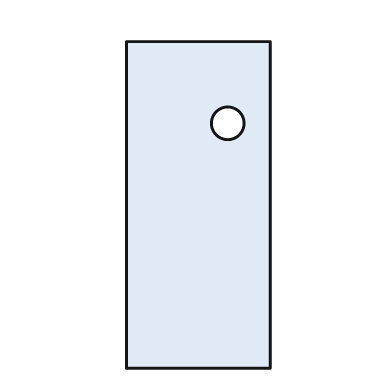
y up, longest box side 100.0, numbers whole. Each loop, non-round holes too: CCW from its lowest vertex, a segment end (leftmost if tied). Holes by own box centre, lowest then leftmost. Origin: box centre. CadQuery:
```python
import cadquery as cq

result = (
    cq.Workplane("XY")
    .moveTo(-22.0, -50.0)
    .lineTo(22.0, -50.0)
    .lineTo(22.0, 50.0)
    .lineTo(-22.0, 50.0)
    .close()
    .moveTo(9.0, 25.0)
    .circle(5.0)
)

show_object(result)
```